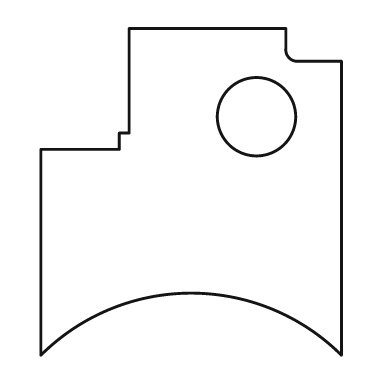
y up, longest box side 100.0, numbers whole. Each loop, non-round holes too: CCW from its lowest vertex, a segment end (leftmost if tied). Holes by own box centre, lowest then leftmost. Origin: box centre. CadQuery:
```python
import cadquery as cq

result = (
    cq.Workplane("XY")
    .moveTo(-46.0, -50.0)
    .threePointArc((0.0, -31.0), (46.0, -50.0))
    .lineTo(46.0, 40.0)
    .lineTo(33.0, 40.0)
    .threePointArc((30.0, 41.0), (29.0, 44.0))
    .lineTo(29.0, 50.0)
    .lineTo(-19.0, 50.0)
    .lineTo(-19.0, 18.0)
    .lineTo(-22.0, 18.0)
    .lineTo(-22.0, 13.0)
    .lineTo(-46.0, 13.0)
    .close()
    .moveTo(20.0, 23.0)
    .circle(12.0)
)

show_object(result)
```